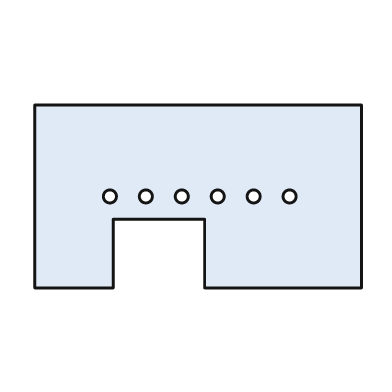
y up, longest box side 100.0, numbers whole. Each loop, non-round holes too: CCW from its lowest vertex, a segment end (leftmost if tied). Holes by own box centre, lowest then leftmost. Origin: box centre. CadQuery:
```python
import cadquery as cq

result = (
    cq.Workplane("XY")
    .moveTo(-50.0, -28.0)
    .lineTo(-26.0, -28.0)
    .lineTo(-26.0, -7.0)
    .lineTo(2.0, -7.0)
    .lineTo(2.0, -28.0)
    .lineTo(50.0, -28.0)
    .lineTo(50.0, 28.0)
    .lineTo(-50.0, 28.0)
    .close()
    .moveTo(-27.0, 0.0)
    .circle(2.0)
    .moveTo(-16.0, 0.0)
    .circle(2.0)
    .moveTo(-5.0, 0.0)
    .circle(2.0)
    .moveTo(6.0, 0.0)
    .circle(2.0)
    .moveTo(17.0, 0.0)
    .circle(2.0)
    .moveTo(28.0, 0.0)
    .circle(2.0)
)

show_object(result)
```